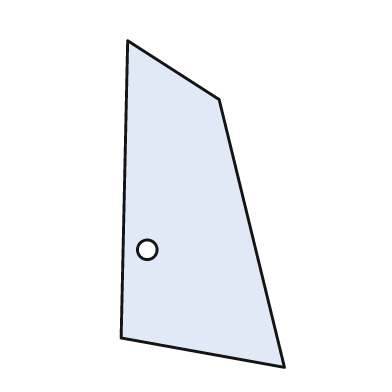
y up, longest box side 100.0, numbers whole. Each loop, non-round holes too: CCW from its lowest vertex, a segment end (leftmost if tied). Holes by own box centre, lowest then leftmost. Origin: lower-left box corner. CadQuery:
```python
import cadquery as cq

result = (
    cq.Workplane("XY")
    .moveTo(50.0, 0.0)
    .lineTo(30.0, 82.0)
    .lineTo(2.0, 100.0)
    .lineTo(0.0, 9.0)
    .close()
    .moveTo(8.0, 36.0)
    .circle(3.0)
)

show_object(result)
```